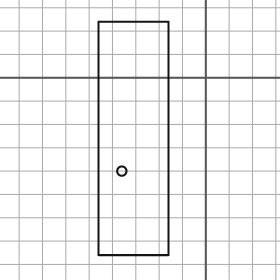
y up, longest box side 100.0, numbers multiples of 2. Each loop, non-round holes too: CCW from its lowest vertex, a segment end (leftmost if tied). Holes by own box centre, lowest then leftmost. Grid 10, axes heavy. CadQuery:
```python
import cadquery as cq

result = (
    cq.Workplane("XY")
    .moveTo(-46.0, -76.0)
    .lineTo(-16.0, -76.0)
    .lineTo(-16.0, 24.0)
    .lineTo(-46.0, 24.0)
    .close()
    .moveTo(-36.0, -40.0)
    .circle(2.0)
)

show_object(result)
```